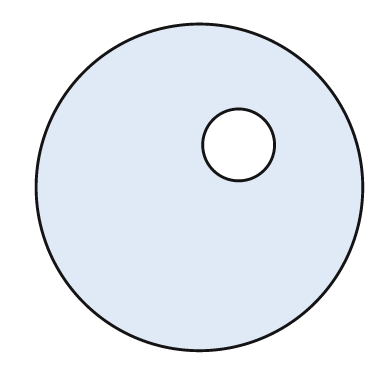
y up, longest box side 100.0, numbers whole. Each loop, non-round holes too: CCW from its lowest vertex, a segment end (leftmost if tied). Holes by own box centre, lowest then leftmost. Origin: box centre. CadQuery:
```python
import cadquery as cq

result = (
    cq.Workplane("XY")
    .moveTo(0.0, 0.0)
    .circle(50.0)
    .moveTo(12.0, 13.0)
    .circle(11.0)
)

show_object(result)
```